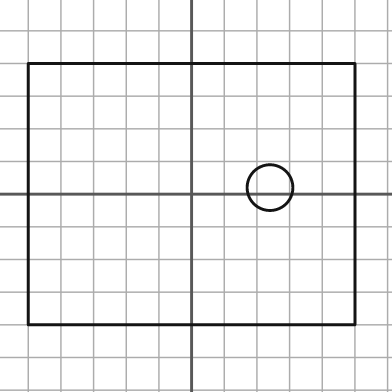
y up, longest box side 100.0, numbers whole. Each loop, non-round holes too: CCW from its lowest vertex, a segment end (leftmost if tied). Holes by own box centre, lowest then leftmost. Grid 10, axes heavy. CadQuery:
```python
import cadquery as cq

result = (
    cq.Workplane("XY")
    .moveTo(-50.0, -40.0)
    .lineTo(50.0, -40.0)
    .lineTo(50.0, 40.0)
    .lineTo(-50.0, 40.0)
    .close()
    .moveTo(24.0, 2.0)
    .circle(7.0)
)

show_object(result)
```